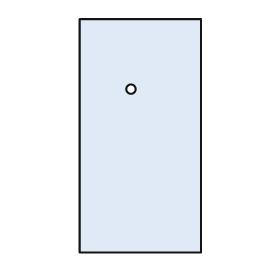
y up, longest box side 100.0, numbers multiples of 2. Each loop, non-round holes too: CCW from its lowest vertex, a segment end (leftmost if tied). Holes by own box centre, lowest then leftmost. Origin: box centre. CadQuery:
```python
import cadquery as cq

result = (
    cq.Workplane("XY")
    .moveTo(-26.0, -50.0)
    .lineTo(26.0, -50.0)
    .lineTo(26.0, 50.0)
    .lineTo(-26.0, 50.0)
    .close()
    .moveTo(-4.0, 20.0)
    .circle(2.0)
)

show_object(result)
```